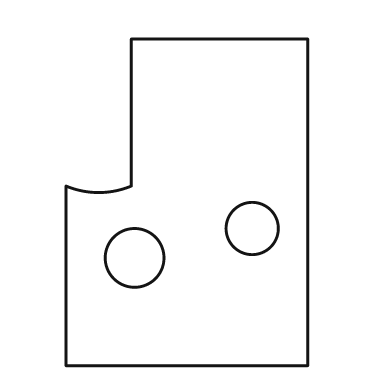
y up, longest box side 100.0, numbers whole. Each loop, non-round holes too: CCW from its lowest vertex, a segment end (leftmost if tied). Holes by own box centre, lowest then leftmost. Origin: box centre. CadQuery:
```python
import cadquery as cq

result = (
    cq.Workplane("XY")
    .moveTo(-37.0, -50.0)
    .lineTo(37.0, -50.0)
    .lineTo(37.0, 50.0)
    .lineTo(-17.0, 50.0)
    .lineTo(-17.0, 5.0)
    .threePointArc((-27.0, 3.0), (-37.0, 5.0))
    .close()
    .moveTo(-16.0, -17.0)
    .circle(9.0)
    .moveTo(20.0, -8.0)
    .circle(8.0)
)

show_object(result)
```